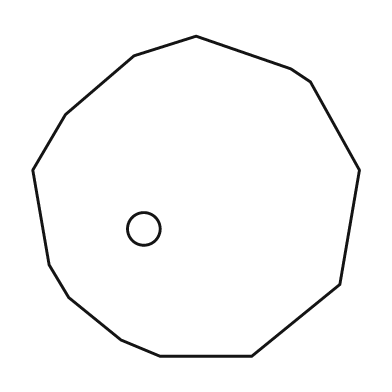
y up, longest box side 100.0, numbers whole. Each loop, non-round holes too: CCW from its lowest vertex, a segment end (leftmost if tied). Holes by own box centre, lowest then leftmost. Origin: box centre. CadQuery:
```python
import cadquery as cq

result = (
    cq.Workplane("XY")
    .moveTo(-11.0, -49.0)
    .lineTo(17.0, -49.0)
    .lineTo(44.0, -27.0)
    .lineTo(50.0, 8.0)
    .lineTo(35.0, 35.0)
    .lineTo(29.0, 39.0)
    .lineTo(0.0, 49.0)
    .lineTo(-19.0, 43.0)
    .lineTo(-40.0, 25.0)
    .lineTo(-50.0, 8.0)
    .lineTo(-45.0, -21.0)
    .lineTo(-39.0, -31.0)
    .lineTo(-23.0, -44.0)
    .close()
    .moveTo(-16.0, -10.0)
    .circle(5.0)
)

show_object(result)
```